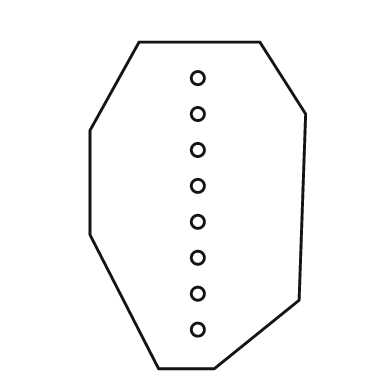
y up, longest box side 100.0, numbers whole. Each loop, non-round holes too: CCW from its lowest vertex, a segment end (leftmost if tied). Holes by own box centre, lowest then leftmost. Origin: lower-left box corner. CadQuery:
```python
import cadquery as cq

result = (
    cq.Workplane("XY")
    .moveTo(21.0, 0.0)
    .lineTo(38.0, 0.0)
    .lineTo(64.0, 21.0)
    .lineTo(66.0, 78.0)
    .lineTo(52.0, 100.0)
    .lineTo(15.0, 100.0)
    .lineTo(0.0, 73.0)
    .lineTo(0.0, 41.0)
    .close()
    .moveTo(33.0, 12.0)
    .circle(2.0)
    .moveTo(33.0, 23.0)
    .circle(2.0)
    .moveTo(33.0, 34.0)
    .circle(2.0)
    .moveTo(33.0, 45.0)
    .circle(2.0)
    .moveTo(33.0, 56.0)
    .circle(2.0)
    .moveTo(33.0, 67.0)
    .circle(2.0)
    .moveTo(33.0, 78.0)
    .circle(2.0)
    .moveTo(33.0, 89.0)
    .circle(2.0)
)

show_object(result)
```